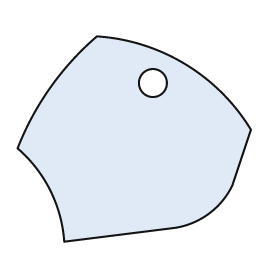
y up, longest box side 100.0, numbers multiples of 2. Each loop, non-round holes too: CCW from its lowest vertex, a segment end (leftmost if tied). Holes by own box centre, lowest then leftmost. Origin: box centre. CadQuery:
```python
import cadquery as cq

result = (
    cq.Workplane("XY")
    .moveTo(-30.0, -44.0)
    .lineTo(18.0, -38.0)
    .threePointArc((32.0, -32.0), (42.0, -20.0))
    .lineTo(50.0, 4.0)
    .threePointArc((22.0, 32.0), (-16.0, 44.0))
    .threePointArc((-36.0, 22.0), (-50.0, -4.0))
    .threePointArc((-36.0, -22.0), (-30.0, -44.0))
    .close()
    .moveTo(8.0, 24.0)
    .circle(6.0)
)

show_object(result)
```